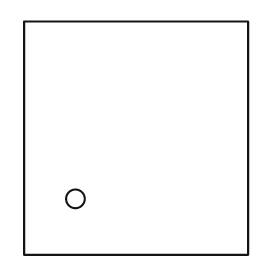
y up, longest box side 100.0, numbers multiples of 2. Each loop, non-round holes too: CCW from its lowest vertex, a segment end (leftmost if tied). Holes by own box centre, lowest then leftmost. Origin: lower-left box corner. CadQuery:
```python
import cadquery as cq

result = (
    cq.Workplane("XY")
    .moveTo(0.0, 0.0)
    .lineTo(96.0, 0.0)
    .lineTo(96.0, 100.0)
    .lineTo(0.0, 100.0)
    .close()
    .moveTo(22.0, 24.0)
    .circle(4.0)
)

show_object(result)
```